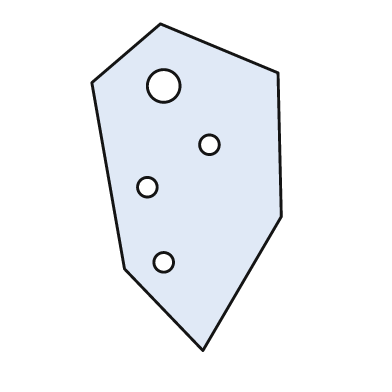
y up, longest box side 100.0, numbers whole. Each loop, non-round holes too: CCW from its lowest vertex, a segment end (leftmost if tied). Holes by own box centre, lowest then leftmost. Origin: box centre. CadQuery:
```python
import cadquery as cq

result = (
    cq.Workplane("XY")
    .moveTo(5.0, -50.0)
    .lineTo(29.0, -9.0)
    .lineTo(28.0, 35.0)
    .lineTo(-8.0, 50.0)
    .lineTo(-29.0, 32.0)
    .lineTo(-19.0, -25.0)
    .close()
    .moveTo(-7.0, -23.0)
    .circle(3.0)
    .moveTo(-12.0, 0.0)
    .circle(3.0)
    .moveTo(7.0, 13.0)
    .circle(3.0)
    .moveTo(-7.0, 31.0)
    .circle(5.0)
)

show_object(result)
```